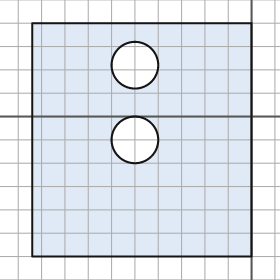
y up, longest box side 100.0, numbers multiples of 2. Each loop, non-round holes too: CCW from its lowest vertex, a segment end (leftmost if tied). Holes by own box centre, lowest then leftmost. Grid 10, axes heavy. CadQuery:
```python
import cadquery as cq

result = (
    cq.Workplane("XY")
    .moveTo(-94.0, -60.0)
    .lineTo(0.0, -60.0)
    .lineTo(0.0, 40.0)
    .lineTo(-94.0, 40.0)
    .close()
    .moveTo(-50.0, -10.0)
    .circle(10.0)
    .moveTo(-50.0, 22.0)
    .circle(10.0)
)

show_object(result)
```